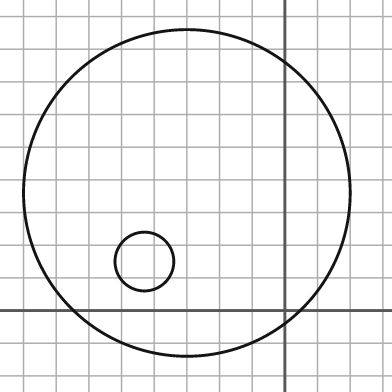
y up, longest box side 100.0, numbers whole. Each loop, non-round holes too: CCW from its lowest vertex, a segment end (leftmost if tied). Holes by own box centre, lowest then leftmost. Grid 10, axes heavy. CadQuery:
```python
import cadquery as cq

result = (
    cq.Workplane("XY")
    .moveTo(-30.0, 36.0)
    .circle(50.0)
    .moveTo(-43.0, 15.0)
    .circle(9.0)
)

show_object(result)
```